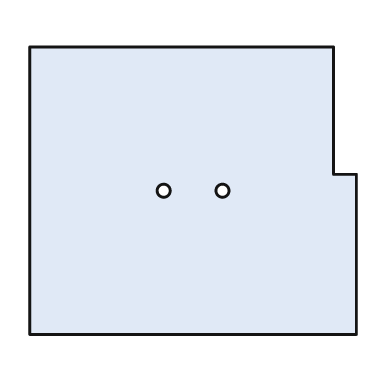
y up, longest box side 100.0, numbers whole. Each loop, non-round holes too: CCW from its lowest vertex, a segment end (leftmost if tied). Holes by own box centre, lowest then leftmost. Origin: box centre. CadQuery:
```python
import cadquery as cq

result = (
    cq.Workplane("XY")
    .moveTo(-50.0, -44.0)
    .lineTo(50.0, -44.0)
    .lineTo(50.0, 5.0)
    .lineTo(43.0, 5.0)
    .lineTo(43.0, 44.0)
    .lineTo(-50.0, 44.0)
    .close()
    .moveTo(-9.0, 0.0)
    .circle(2.0)
    .moveTo(9.0, 0.0)
    .circle(2.0)
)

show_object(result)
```